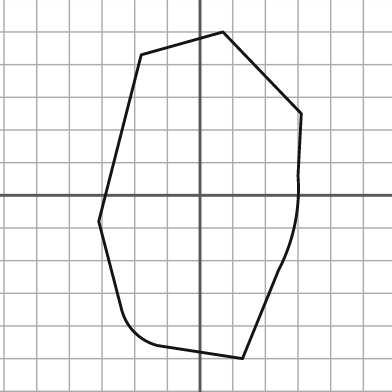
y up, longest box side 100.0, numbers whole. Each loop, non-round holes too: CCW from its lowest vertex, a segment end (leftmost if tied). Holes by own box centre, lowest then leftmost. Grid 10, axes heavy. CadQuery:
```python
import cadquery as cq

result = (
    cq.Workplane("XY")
    .moveTo(13.0, -50.0)
    .lineTo(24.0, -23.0)
    .threePointArc((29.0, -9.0), (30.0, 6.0))
    .lineTo(31.0, 25.0)
    .lineTo(7.0, 50.0)
    .lineTo(-18.0, 43.0)
    .lineTo(-31.0, -8.0)
    .lineTo(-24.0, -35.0)
    .threePointArc((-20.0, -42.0), (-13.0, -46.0))
    .close()
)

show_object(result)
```